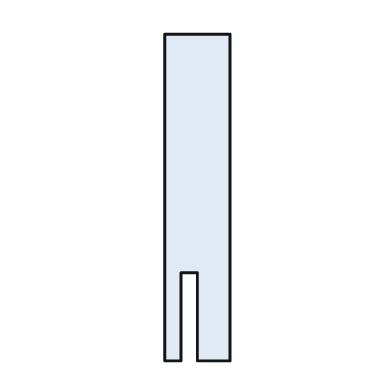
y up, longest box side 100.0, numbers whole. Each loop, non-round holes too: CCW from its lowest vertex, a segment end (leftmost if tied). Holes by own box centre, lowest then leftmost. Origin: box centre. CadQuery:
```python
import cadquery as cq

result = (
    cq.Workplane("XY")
    .moveTo(-10.0, -50.0)
    .lineTo(-5.0, -50.0)
    .lineTo(-5.0, -23.0)
    .lineTo(0.0, -23.0)
    .lineTo(0.0, -50.0)
    .lineTo(10.0, -50.0)
    .lineTo(10.0, 50.0)
    .lineTo(-10.0, 50.0)
    .close()
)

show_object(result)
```